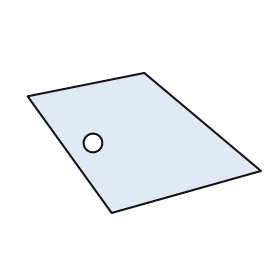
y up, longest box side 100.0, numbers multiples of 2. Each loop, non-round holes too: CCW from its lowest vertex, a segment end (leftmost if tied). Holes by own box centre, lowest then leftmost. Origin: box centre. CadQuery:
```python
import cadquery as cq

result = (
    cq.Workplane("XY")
    .moveTo(-14.0, -30.0)
    .lineTo(50.0, -12.0)
    .lineTo(0.0, 30.0)
    .lineTo(-50.0, 20.0)
    .close()
    .moveTo(-22.0, 0.0)
    .circle(4.0)
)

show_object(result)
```